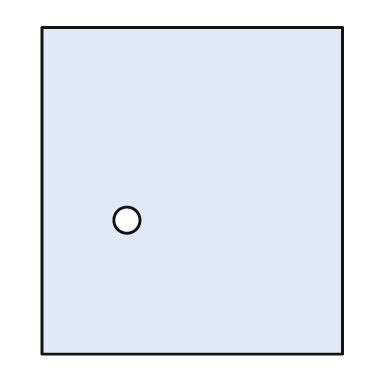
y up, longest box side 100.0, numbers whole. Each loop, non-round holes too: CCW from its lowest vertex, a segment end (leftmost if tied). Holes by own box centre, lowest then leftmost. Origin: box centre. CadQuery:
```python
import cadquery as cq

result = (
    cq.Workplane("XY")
    .moveTo(-46.0, -50.0)
    .lineTo(46.0, -50.0)
    .lineTo(46.0, 50.0)
    .lineTo(-46.0, 50.0)
    .close()
    .moveTo(-20.0, -9.0)
    .circle(4.0)
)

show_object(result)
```